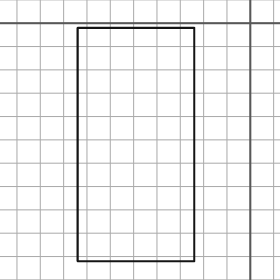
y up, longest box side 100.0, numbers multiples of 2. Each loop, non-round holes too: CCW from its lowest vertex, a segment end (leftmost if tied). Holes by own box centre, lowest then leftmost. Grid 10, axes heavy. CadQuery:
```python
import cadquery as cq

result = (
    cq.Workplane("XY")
    .moveTo(-74.0, -102.0)
    .lineTo(-24.0, -102.0)
    .lineTo(-24.0, -2.0)
    .lineTo(-74.0, -2.0)
    .close()
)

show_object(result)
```